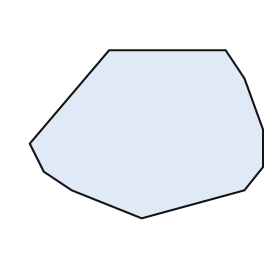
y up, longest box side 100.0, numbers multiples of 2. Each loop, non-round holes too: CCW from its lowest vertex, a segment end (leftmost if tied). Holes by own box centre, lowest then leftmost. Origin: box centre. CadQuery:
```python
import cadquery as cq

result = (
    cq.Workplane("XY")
    .moveTo(-2.0, -36.0)
    .lineTo(42.0, -24.0)
    .lineTo(50.0, -14.0)
    .lineTo(50.0, 2.0)
    .lineTo(42.0, 24.0)
    .lineTo(34.0, 36.0)
    .lineTo(-16.0, 36.0)
    .lineTo(-50.0, -4.0)
    .lineTo(-44.0, -16.0)
    .lineTo(-32.0, -24.0)
    .close()
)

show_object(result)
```